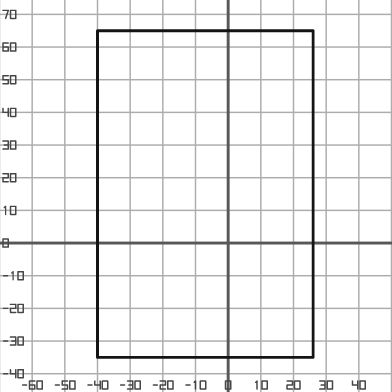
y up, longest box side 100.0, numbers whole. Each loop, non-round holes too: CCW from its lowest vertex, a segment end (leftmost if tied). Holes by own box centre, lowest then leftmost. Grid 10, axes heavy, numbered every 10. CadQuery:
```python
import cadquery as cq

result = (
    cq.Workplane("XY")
    .moveTo(-40.0, -35.0)
    .lineTo(26.0, -35.0)
    .lineTo(26.0, 65.0)
    .lineTo(-40.0, 65.0)
    .close()
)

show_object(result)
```